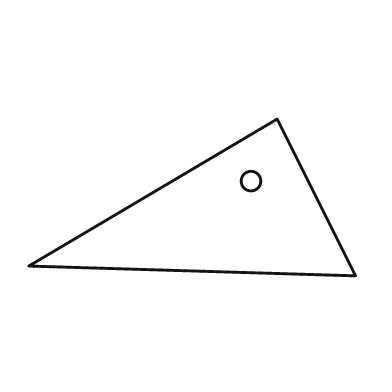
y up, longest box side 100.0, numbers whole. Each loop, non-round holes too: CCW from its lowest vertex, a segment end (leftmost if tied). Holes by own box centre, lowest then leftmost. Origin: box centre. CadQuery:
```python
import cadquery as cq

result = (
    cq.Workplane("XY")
    .moveTo(50.0, -24.0)
    .lineTo(26.0, 24.0)
    .lineTo(-50.0, -21.0)
    .close()
    .moveTo(18.0, 5.0)
    .circle(3.0)
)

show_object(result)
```